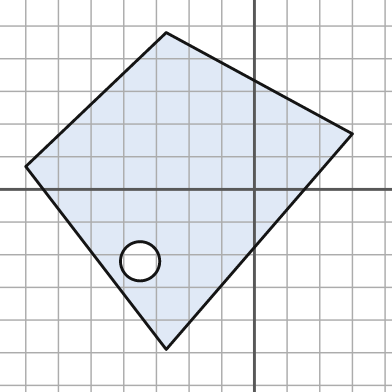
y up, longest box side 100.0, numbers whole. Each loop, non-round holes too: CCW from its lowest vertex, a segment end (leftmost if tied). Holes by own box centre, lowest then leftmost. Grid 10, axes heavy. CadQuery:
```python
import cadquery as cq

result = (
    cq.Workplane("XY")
    .moveTo(-27.0, -49.0)
    .lineTo(30.0, 17.0)
    .lineTo(-27.0, 48.0)
    .lineTo(-70.0, 7.0)
    .close()
    .moveTo(-35.0, -22.0)
    .circle(6.0)
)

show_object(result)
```